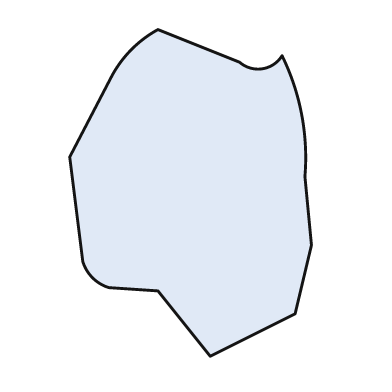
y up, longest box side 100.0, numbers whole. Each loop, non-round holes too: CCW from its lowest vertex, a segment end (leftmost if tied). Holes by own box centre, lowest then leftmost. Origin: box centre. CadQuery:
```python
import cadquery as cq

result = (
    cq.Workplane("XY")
    .moveTo(6.0, -50.0)
    .lineTo(32.0, -37.0)
    .lineTo(37.0, -16.0)
    .lineTo(35.0, 5.0)
    .threePointArc((34.0, 24.0), (28.0, 42.0))
    .threePointArc((22.0, 38.0), (15.0, 40.0))
    .lineTo(-10.0, 50.0)
    .threePointArc((-18.0, 44.0), (-24.0, 36.0))
    .lineTo(-37.0, 11.0)
    .lineTo(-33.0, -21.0)
    .threePointArc((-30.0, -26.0), (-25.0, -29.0))
    .lineTo(-10.0, -30.0)
    .close()
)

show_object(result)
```